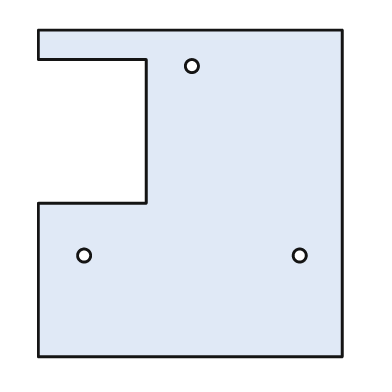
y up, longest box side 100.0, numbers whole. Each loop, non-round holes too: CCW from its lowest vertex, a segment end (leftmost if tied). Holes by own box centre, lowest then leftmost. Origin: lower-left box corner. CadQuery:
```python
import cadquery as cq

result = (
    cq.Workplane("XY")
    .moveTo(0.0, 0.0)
    .lineTo(93.0, 0.0)
    .lineTo(93.0, 100.0)
    .lineTo(0.0, 100.0)
    .lineTo(0.0, 91.0)
    .lineTo(33.0, 91.0)
    .lineTo(33.0, 47.0)
    .lineTo(0.0, 47.0)
    .close()
    .moveTo(14.0, 31.0)
    .circle(2.0)
    .moveTo(80.0, 31.0)
    .circle(2.0)
    .moveTo(47.0, 89.0)
    .circle(2.0)
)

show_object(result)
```